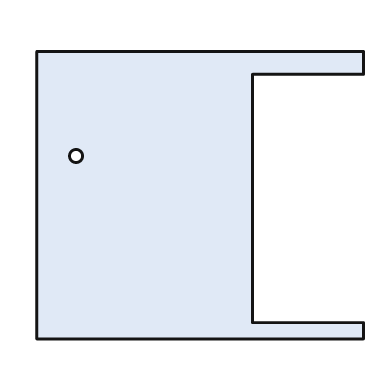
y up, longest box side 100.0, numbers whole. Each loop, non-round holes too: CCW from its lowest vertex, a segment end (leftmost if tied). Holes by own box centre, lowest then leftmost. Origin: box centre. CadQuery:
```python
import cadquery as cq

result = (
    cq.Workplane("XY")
    .moveTo(-50.0, -44.0)
    .lineTo(50.0, -44.0)
    .lineTo(50.0, -39.0)
    .lineTo(16.0, -39.0)
    .lineTo(16.0, 37.0)
    .lineTo(50.0, 37.0)
    .lineTo(50.0, 44.0)
    .lineTo(-50.0, 44.0)
    .close()
    .moveTo(-38.0, 12.0)
    .circle(2.0)
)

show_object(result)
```